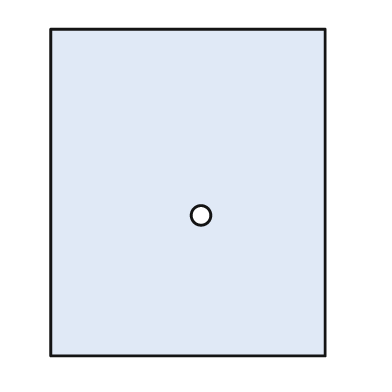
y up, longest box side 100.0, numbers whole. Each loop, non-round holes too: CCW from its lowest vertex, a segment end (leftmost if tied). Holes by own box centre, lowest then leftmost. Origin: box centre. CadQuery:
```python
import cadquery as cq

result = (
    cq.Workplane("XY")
    .moveTo(-42.0, -50.0)
    .lineTo(42.0, -50.0)
    .lineTo(42.0, 50.0)
    .lineTo(-42.0, 50.0)
    .close()
    .moveTo(4.0, -7.0)
    .circle(3.0)
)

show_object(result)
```